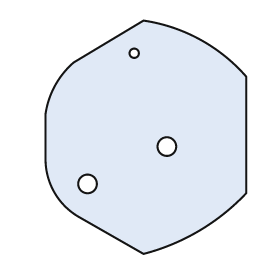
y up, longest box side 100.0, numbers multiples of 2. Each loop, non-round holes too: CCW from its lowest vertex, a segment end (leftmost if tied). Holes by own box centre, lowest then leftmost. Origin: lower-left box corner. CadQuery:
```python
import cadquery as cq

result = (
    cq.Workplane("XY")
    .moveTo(42.0, 0.0)
    .threePointArc((66.0, 10.0), (86.0, 26.0))
    .lineTo(86.0, 76.0)
    .threePointArc((66.0, 92.0), (42.0, 100.0))
    .lineTo(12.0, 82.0)
    .threePointArc((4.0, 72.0), (0.0, 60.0))
    .lineTo(0.0, 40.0)
    .threePointArc((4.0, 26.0), (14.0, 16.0))
    .close()
    .moveTo(18.0, 30.0)
    .circle(4.0)
    .moveTo(52.0, 46.0)
    .circle(4.0)
    .moveTo(38.0, 86.0)
    .circle(2.0)
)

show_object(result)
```